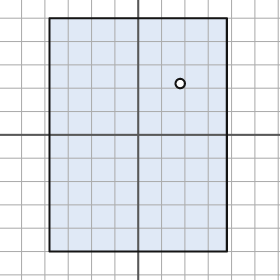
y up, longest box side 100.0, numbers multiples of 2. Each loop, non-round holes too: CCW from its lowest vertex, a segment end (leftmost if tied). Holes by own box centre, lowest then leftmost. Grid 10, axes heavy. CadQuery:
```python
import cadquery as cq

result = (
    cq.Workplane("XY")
    .moveTo(-38.0, -50.0)
    .lineTo(38.0, -50.0)
    .lineTo(38.0, 50.0)
    .lineTo(-38.0, 50.0)
    .close()
    .moveTo(18.0, 22.0)
    .circle(2.0)
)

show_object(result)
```